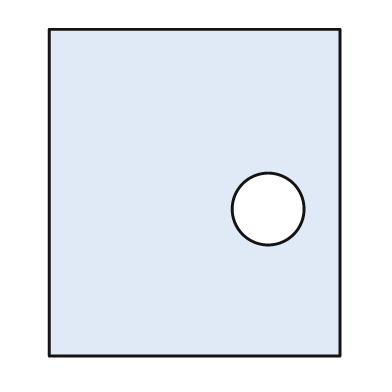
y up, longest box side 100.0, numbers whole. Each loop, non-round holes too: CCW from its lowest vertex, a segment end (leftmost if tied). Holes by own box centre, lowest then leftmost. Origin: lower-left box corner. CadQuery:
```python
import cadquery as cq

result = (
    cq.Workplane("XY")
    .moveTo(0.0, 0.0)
    .lineTo(89.0, 0.0)
    .lineTo(89.0, 100.0)
    .lineTo(0.0, 100.0)
    .close()
    .moveTo(67.0, 45.0)
    .circle(11.0)
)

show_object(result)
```